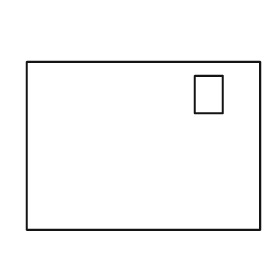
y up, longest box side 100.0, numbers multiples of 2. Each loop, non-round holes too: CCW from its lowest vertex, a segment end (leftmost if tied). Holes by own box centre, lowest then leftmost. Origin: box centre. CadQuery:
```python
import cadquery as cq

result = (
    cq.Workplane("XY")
    .moveTo(-50.0, -36.0)
    .lineTo(50.0, -36.0)
    .lineTo(50.0, 36.0)
    .lineTo(-50.0, 36.0)
    .close()
    .moveTo(22.0, 14.0)
    .lineTo(34.0, 14.0)
    .lineTo(34.0, 30.0)
    .lineTo(22.0, 30.0)
    .close()
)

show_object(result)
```